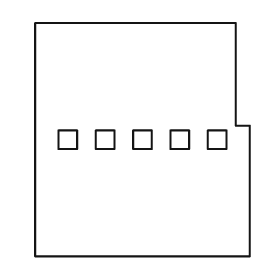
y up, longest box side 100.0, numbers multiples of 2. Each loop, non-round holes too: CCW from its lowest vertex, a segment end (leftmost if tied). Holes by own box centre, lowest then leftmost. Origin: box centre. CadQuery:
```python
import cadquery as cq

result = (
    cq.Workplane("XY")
    .moveTo(-46.0, -50.0)
    .lineTo(46.0, -50.0)
    .lineTo(46.0, 6.0)
    .lineTo(40.0, 6.0)
    .lineTo(40.0, 50.0)
    .lineTo(-46.0, 50.0)
    .close()
    .moveTo(-36.0, -4.0)
    .lineTo(-28.0, -4.0)
    .lineTo(-28.0, 4.0)
    .lineTo(-36.0, 4.0)
    .close()
    .moveTo(-20.0, -4.0)
    .lineTo(-12.0, -4.0)
    .lineTo(-12.0, 4.0)
    .lineTo(-20.0, 4.0)
    .close()
    .moveTo(-4.0, -4.0)
    .lineTo(4.0, -4.0)
    .lineTo(4.0, 4.0)
    .lineTo(-4.0, 4.0)
    .close()
    .moveTo(12.0, -4.0)
    .lineTo(20.0, -4.0)
    .lineTo(20.0, 4.0)
    .lineTo(12.0, 4.0)
    .close()
    .moveTo(28.0, -4.0)
    .lineTo(36.0, -4.0)
    .lineTo(36.0, 4.0)
    .lineTo(28.0, 4.0)
    .close()
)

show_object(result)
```